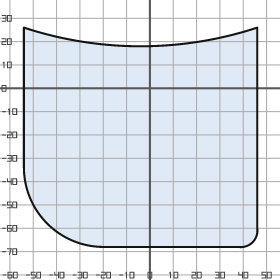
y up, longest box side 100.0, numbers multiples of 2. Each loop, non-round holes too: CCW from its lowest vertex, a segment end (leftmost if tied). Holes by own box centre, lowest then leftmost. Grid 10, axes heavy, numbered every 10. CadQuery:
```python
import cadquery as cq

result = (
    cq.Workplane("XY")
    .moveTo(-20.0, -68.0)
    .lineTo(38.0, -68.0)
    .threePointArc((44.0, -66.0), (46.0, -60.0))
    .lineTo(46.0, 26.0)
    .threePointArc((-4.0, 18.0), (-54.0, 26.0))
    .lineTo(-54.0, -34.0)
    .threePointArc((-44.0, -58.0), (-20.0, -68.0))
    .close()
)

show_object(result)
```